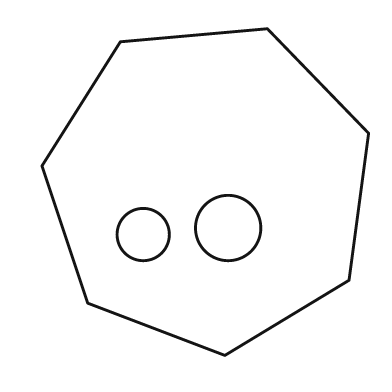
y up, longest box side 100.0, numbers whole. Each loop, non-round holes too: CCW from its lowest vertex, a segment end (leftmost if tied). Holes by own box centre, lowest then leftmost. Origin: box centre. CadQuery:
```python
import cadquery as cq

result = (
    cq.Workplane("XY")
    .moveTo(6.0, -50.0)
    .lineTo(44.0, -27.0)
    .lineTo(50.0, 18.0)
    .lineTo(19.0, 50.0)
    .lineTo(-26.0, 46.0)
    .lineTo(-50.0, 8.0)
    .lineTo(-36.0, -34.0)
    .close()
    .moveTo(-19.0, -13.0)
    .circle(8.0)
    .moveTo(7.0, -11.0)
    .circle(10.0)
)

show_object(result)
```